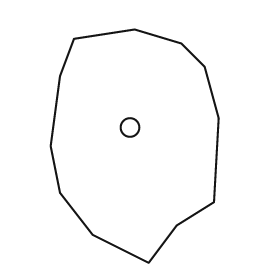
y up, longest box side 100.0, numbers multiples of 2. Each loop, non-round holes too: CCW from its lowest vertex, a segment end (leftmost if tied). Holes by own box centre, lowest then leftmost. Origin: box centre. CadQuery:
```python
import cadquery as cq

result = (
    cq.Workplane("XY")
    .moveTo(6.0, -50.0)
    .lineTo(18.0, -34.0)
    .lineTo(34.0, -24.0)
    .lineTo(36.0, 12.0)
    .lineTo(30.0, 34.0)
    .lineTo(20.0, 44.0)
    .lineTo(0.0, 50.0)
    .lineTo(-26.0, 46.0)
    .lineTo(-32.0, 30.0)
    .lineTo(-36.0, 0.0)
    .lineTo(-32.0, -20.0)
    .lineTo(-18.0, -38.0)
    .close()
    .moveTo(-2.0, 8.0)
    .circle(4.0)
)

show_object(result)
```